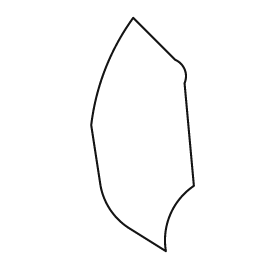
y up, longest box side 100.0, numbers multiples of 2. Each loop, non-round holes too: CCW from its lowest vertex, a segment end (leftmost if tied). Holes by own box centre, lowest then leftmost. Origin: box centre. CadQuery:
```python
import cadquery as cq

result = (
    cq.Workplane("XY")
    .moveTo(10.0, -50.0)
    .threePointArc((12.0, -34.0), (22.0, -22.0))
    .lineTo(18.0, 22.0)
    .threePointArc((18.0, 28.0), (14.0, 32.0))
    .lineTo(-4.0, 50.0)
    .threePointArc((-16.0, 28.0), (-22.0, 4.0))
    .lineTo(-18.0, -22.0)
    .threePointArc((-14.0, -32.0), (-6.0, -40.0))
    .close()
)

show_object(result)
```